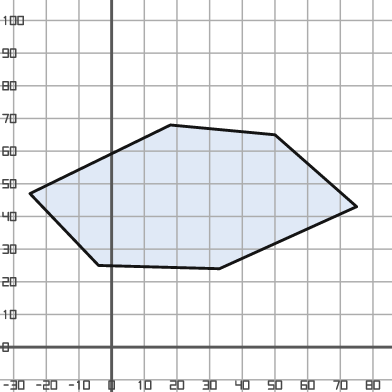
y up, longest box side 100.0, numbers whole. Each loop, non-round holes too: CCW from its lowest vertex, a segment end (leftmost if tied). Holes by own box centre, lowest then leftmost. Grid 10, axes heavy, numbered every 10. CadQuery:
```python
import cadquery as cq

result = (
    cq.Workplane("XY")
    .moveTo(33.0, 24.0)
    .lineTo(75.0, 43.0)
    .lineTo(50.0, 65.0)
    .lineTo(18.0, 68.0)
    .lineTo(-25.0, 47.0)
    .lineTo(-4.0, 25.0)
    .close()
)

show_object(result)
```